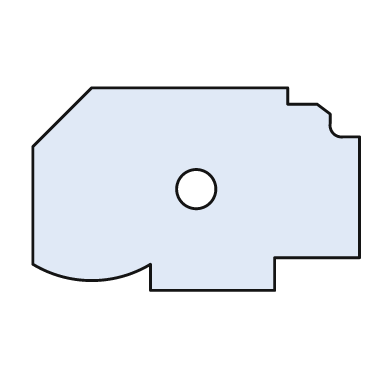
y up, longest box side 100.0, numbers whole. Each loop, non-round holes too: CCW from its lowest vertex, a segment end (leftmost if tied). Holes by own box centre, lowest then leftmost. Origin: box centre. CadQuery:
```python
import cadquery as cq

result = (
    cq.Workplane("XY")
    .moveTo(-14.0, -31.0)
    .lineTo(24.0, -31.0)
    .lineTo(24.0, -21.0)
    .lineTo(50.0, -21.0)
    .lineTo(50.0, 16.0)
    .lineTo(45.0, 16.0)
    .threePointArc((42.0, 17.0), (41.0, 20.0))
    .lineTo(41.0, 23.0)
    .lineTo(37.0, 26.0)
    .lineTo(28.0, 26.0)
    .lineTo(28.0, 31.0)
    .lineTo(-32.0, 31.0)
    .lineTo(-50.0, 13.0)
    .lineTo(-50.0, -23.0)
    .threePointArc((-32.0, -28.0), (-14.0, -23.0))
    .close()
    .moveTo(0.0, 0.0)
    .circle(6.0)
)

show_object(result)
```